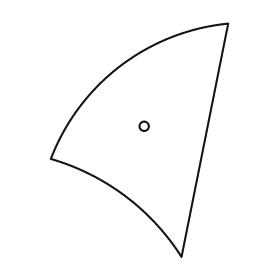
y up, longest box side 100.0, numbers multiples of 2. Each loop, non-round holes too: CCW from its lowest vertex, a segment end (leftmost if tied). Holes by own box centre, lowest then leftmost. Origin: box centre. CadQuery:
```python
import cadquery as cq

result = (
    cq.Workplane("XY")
    .moveTo(18.0, -50.0)
    .lineTo(38.0, 50.0)
    .threePointArc((-8.0, 32.0), (-38.0, -8.0))
    .threePointArc((-6.0, -24.0), (18.0, -50.0))
    .close()
    .moveTo(2.0, 6.0)
    .circle(2.0)
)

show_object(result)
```